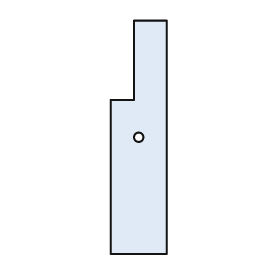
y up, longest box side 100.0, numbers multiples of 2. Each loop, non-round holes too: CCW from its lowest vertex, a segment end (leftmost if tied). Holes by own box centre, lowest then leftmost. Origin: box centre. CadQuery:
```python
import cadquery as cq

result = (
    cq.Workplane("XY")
    .moveTo(-12.0, -50.0)
    .lineTo(12.0, -50.0)
    .lineTo(12.0, 50.0)
    .lineTo(-2.0, 50.0)
    .lineTo(-2.0, 16.0)
    .lineTo(-12.0, 16.0)
    .close()
    .moveTo(0.0, 0.0)
    .circle(2.0)
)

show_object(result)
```